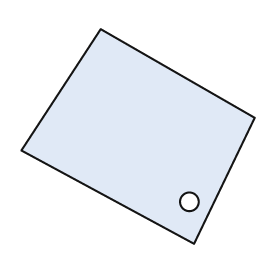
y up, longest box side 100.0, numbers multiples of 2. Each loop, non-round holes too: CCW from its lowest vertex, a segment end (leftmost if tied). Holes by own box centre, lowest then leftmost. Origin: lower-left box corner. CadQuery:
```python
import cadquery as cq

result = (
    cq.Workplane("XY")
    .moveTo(74.0, 0.0)
    .lineTo(100.0, 54.0)
    .lineTo(34.0, 92.0)
    .lineTo(0.0, 40.0)
    .close()
    .moveTo(72.0, 18.0)
    .circle(4.0)
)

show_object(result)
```